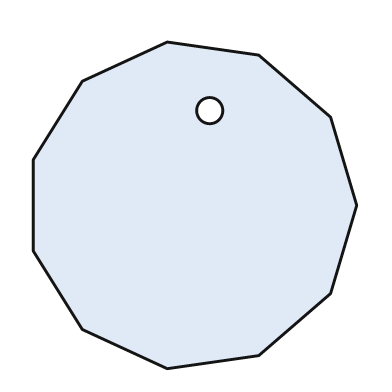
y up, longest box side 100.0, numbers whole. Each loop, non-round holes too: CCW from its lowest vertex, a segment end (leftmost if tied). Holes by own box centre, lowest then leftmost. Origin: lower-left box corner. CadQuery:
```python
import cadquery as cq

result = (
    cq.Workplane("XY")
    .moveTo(41.0, 0.0)
    .lineTo(69.0, 4.0)
    .lineTo(91.0, 23.0)
    .lineTo(99.0, 50.0)
    .lineTo(91.0, 77.0)
    .lineTo(69.0, 96.0)
    .lineTo(41.0, 100.0)
    .lineTo(15.0, 88.0)
    .lineTo(0.0, 64.0)
    .lineTo(0.0, 36.0)
    .lineTo(15.0, 12.0)
    .close()
    .moveTo(54.0, 79.0)
    .circle(4.0)
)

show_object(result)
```